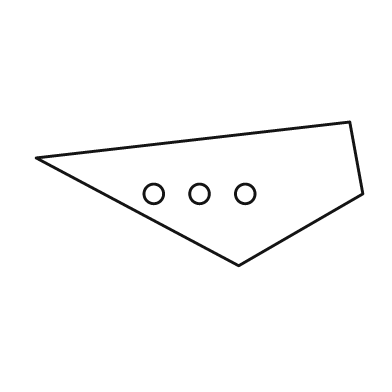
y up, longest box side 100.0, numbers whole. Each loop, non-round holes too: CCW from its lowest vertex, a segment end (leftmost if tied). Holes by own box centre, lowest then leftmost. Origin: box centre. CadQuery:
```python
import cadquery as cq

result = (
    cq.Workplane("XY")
    .moveTo(12.0, -22.0)
    .lineTo(50.0, 0.0)
    .lineTo(46.0, 22.0)
    .lineTo(-50.0, 11.0)
    .close()
    .moveTo(-14.0, 0.0)
    .circle(3.0)
    .moveTo(0.0, 0.0)
    .circle(3.0)
    .moveTo(14.0, 0.0)
    .circle(3.0)
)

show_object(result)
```